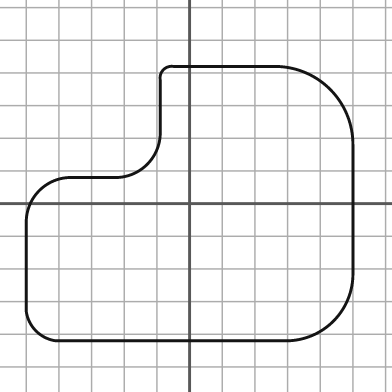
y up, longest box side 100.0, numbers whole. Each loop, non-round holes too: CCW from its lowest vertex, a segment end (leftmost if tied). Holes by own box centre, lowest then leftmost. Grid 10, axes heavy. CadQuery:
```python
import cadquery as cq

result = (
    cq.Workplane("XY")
    .moveTo(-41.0, -42.0)
    .lineTo(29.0, -42.0)
    .threePointArc((44.0, -36.0), (50.0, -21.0))
    .lineTo(50.0, 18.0)
    .threePointArc((43.0, 35.0), (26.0, 42.0))
    .lineTo(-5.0, 42.0)
    .threePointArc((-8.0, 41.0), (-9.0, 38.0))
    .lineTo(-9.0, 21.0)
    .threePointArc((-13.0, 12.0), (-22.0, 8.0))
    .lineTo(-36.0, 8.0)
    .threePointArc((-46.0, 4.0), (-50.0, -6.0))
    .lineTo(-50.0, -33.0)
    .threePointArc((-47.0, -39.0), (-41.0, -42.0))
    .close()
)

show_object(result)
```